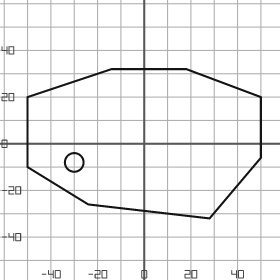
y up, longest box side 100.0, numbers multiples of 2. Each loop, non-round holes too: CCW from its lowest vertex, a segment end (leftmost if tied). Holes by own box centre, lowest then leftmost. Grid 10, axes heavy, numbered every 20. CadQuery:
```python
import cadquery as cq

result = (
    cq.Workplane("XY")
    .moveTo(28.0, -32.0)
    .lineTo(50.0, -6.0)
    .lineTo(50.0, 20.0)
    .lineTo(18.0, 32.0)
    .lineTo(-14.0, 32.0)
    .lineTo(-50.0, 20.0)
    .lineTo(-50.0, -10.0)
    .lineTo(-24.0, -26.0)
    .close()
    .moveTo(-30.0, -8.0)
    .circle(4.0)
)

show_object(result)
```